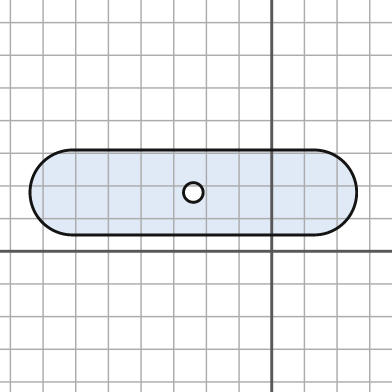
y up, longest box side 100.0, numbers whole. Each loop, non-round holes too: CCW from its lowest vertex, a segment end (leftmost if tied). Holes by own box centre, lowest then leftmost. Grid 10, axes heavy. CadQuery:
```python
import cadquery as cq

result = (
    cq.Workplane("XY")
    .moveTo(-61.0, 5.0)
    .lineTo(13.0, 5.0)
    .threePointArc((26.0, 18.0), (13.0, 31.0))
    .lineTo(-61.0, 31.0)
    .threePointArc((-74.0, 18.0), (-61.0, 5.0))
    .close()
    .moveTo(-24.0, 18.0)
    .circle(3.0)
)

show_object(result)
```